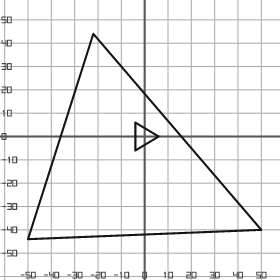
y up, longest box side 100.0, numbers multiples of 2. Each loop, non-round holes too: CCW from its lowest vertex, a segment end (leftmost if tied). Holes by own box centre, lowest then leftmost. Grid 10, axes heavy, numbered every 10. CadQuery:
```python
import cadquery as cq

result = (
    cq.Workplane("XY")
    .moveTo(-50.0, -44.0)
    .lineTo(50.0, -40.0)
    .lineTo(-22.0, 44.0)
    .close()
    .moveTo(-4.0, -6.0)
    .lineTo(6.0, 0.0)
    .lineTo(-4.0, 6.0)
    .close()
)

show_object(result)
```